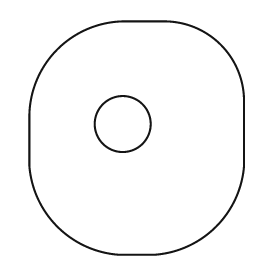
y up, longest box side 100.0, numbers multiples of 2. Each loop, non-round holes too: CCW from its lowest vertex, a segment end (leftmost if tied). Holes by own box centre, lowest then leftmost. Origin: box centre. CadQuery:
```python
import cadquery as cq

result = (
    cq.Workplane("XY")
    .moveTo(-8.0, -50.0)
    .lineTo(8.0, -50.0)
    .threePointArc((34.0, -38.0), (46.0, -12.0))
    .lineTo(46.0, 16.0)
    .threePointArc((36.0, 40.0), (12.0, 50.0))
    .lineTo(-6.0, 50.0)
    .threePointArc((-34.0, 38.0), (-46.0, 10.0))
    .lineTo(-46.0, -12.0)
    .threePointArc((-34.0, -38.0), (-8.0, -50.0))
    .close()
    .moveTo(-6.0, 6.0)
    .circle(12.0)
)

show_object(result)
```